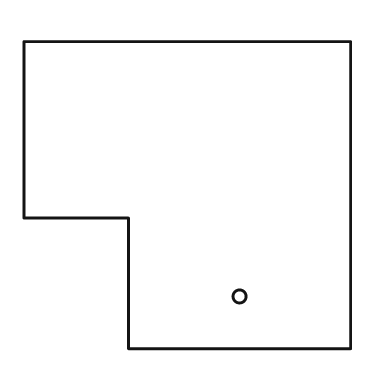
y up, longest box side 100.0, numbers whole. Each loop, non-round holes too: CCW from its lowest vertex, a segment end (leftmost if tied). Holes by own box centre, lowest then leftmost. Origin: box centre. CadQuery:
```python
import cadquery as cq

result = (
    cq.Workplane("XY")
    .moveTo(-18.0, -47.0)
    .lineTo(50.0, -47.0)
    .lineTo(50.0, 47.0)
    .lineTo(-50.0, 47.0)
    .lineTo(-50.0, -7.0)
    .lineTo(-18.0, -7.0)
    .close()
    .moveTo(16.0, -31.0)
    .circle(2.0)
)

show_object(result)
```